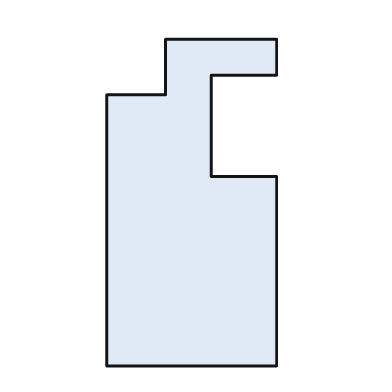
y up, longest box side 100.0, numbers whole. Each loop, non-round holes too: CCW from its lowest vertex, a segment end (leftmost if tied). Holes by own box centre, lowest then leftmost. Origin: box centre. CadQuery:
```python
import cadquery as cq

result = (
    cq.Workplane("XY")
    .moveTo(-26.0, -50.0)
    .lineTo(26.0, -50.0)
    .lineTo(26.0, 8.0)
    .lineTo(6.0, 8.0)
    .lineTo(6.0, 39.0)
    .lineTo(26.0, 39.0)
    .lineTo(26.0, 50.0)
    .lineTo(-8.0, 50.0)
    .lineTo(-8.0, 33.0)
    .lineTo(-26.0, 33.0)
    .close()
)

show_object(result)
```